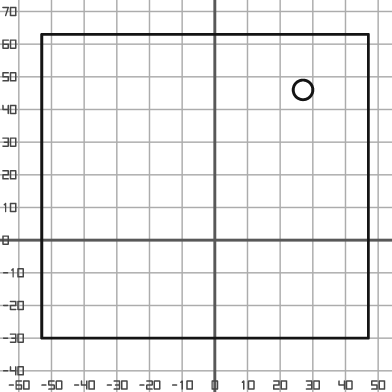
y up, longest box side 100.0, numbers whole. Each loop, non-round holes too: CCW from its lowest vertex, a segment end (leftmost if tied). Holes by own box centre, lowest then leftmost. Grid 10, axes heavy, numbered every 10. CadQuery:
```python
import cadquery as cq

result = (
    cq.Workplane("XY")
    .moveTo(-53.0, -30.0)
    .lineTo(47.0, -30.0)
    .lineTo(47.0, 63.0)
    .lineTo(-53.0, 63.0)
    .close()
    .moveTo(27.0, 46.0)
    .circle(3.0)
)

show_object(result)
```